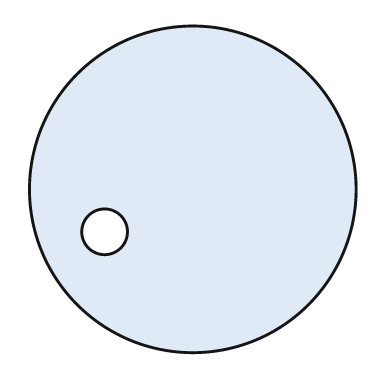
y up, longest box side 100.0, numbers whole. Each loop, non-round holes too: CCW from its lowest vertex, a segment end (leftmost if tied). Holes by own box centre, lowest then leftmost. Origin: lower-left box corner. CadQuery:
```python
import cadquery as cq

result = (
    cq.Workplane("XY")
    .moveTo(50.0, 50.0)
    .circle(50.0)
    .moveTo(23.0, 37.0)
    .circle(7.0)
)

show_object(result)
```